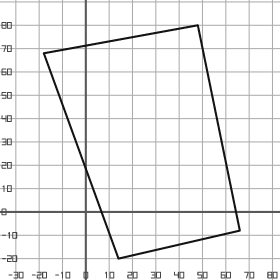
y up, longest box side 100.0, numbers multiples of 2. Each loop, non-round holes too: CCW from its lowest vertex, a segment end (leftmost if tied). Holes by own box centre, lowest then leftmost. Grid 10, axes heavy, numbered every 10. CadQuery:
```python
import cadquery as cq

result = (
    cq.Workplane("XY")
    .moveTo(14.0, -20.0)
    .lineTo(66.0, -8.0)
    .lineTo(48.0, 80.0)
    .lineTo(-18.0, 68.0)
    .close()
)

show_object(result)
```